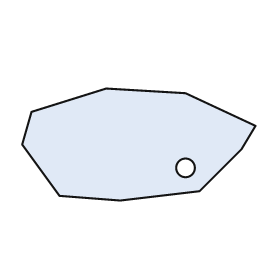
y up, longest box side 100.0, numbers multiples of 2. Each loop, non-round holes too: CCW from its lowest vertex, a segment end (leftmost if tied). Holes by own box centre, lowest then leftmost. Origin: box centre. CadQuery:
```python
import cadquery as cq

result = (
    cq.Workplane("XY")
    .moveTo(-8.0, -24.0)
    .lineTo(26.0, -20.0)
    .lineTo(44.0, -2.0)
    .lineTo(50.0, 8.0)
    .lineTo(20.0, 22.0)
    .lineTo(-14.0, 24.0)
    .lineTo(-46.0, 14.0)
    .lineTo(-50.0, 0.0)
    .lineTo(-34.0, -22.0)
    .close()
    .moveTo(20.0, -10.0)
    .circle(4.0)
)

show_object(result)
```